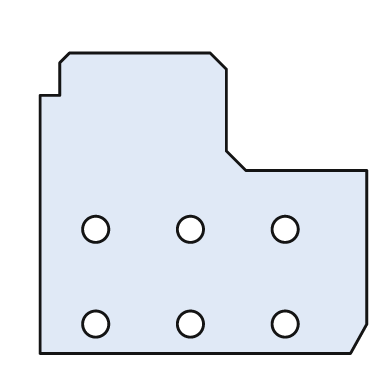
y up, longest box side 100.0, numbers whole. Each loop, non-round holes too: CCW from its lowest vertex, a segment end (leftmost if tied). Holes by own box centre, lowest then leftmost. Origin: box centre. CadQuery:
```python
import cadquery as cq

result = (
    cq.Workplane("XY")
    .moveTo(-50.0, -46.0)
    .lineTo(45.0, -46.0)
    .lineTo(50.0, -37.0)
    .lineTo(50.0, 10.0)
    .lineTo(13.0, 10.0)
    .lineTo(7.0, 16.0)
    .lineTo(7.0, 41.0)
    .lineTo(2.0, 46.0)
    .lineTo(-41.0, 46.0)
    .lineTo(-44.0, 43.0)
    .lineTo(-44.0, 33.0)
    .lineTo(-50.0, 33.0)
    .close()
    .moveTo(-33.0, -37.0)
    .circle(4.0)
    .moveTo(-4.0, -37.0)
    .circle(4.0)
    .moveTo(25.0, -37.0)
    .circle(4.0)
    .moveTo(-33.0, -8.0)
    .circle(4.0)
    .moveTo(-4.0, -8.0)
    .circle(4.0)
    .moveTo(25.0, -8.0)
    .circle(4.0)
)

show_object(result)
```